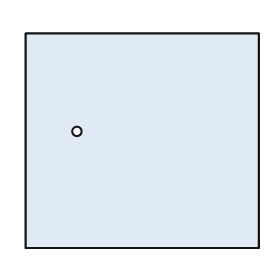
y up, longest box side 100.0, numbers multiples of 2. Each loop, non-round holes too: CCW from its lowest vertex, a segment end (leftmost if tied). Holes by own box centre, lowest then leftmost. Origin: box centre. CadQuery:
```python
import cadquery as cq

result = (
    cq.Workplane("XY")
    .moveTo(-50.0, -46.0)
    .lineTo(50.0, -46.0)
    .lineTo(50.0, 46.0)
    .lineTo(-50.0, 46.0)
    .close()
    .moveTo(-28.0, 4.0)
    .circle(2.0)
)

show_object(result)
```